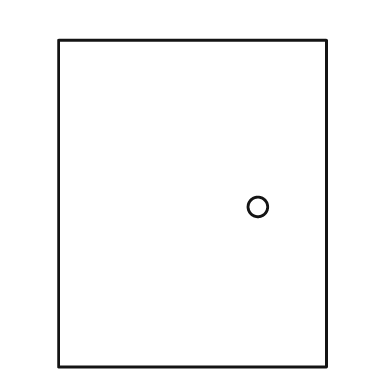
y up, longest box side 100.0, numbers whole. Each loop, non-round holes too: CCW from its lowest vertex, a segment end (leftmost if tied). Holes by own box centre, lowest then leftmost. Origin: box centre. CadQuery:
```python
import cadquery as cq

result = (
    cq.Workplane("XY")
    .moveTo(-41.0, -50.0)
    .lineTo(41.0, -50.0)
    .lineTo(41.0, 50.0)
    .lineTo(-41.0, 50.0)
    .close()
    .moveTo(20.0, -1.0)
    .circle(3.0)
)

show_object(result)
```